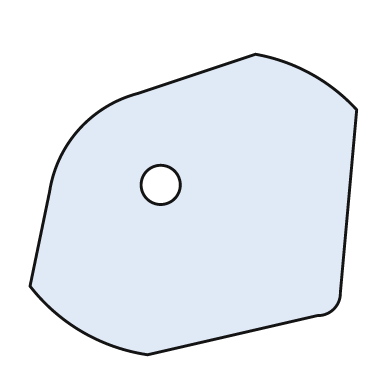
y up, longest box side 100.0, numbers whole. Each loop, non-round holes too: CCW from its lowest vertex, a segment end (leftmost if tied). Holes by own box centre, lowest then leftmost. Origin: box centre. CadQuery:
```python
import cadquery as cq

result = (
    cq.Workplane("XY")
    .moveTo(-14.0, -46.0)
    .lineTo(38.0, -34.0)
    .threePointArc((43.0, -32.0), (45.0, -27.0))
    .lineTo(50.0, 29.0)
    .threePointArc((36.0, 40.0), (19.0, 46.0))
    .lineTo(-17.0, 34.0)
    .threePointArc((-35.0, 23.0), (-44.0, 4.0))
    .lineTo(-50.0, -25.0)
    .threePointArc((-34.0, -39.0), (-14.0, -46.0))
    .close()
    .moveTo(-10.0, 6.0)
    .circle(6.0)
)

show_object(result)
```